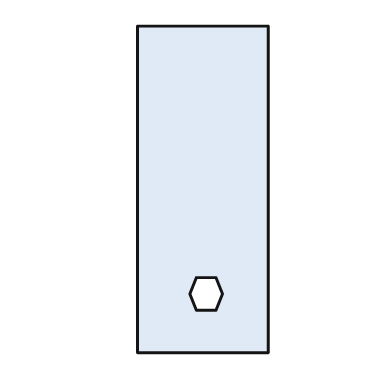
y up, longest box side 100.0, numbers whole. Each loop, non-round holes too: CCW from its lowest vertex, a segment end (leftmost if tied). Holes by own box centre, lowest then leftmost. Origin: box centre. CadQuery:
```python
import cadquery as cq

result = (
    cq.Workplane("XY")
    .moveTo(-20.0, -50.0)
    .lineTo(20.0, -50.0)
    .lineTo(20.0, 50.0)
    .lineTo(-20.0, 50.0)
    .close()
    .moveTo(-2.0, -37.0)
    .lineTo(4.0, -37.0)
    .lineTo(6.0, -32.0)
    .lineTo(4.0, -27.0)
    .lineTo(-2.0, -27.0)
    .lineTo(-4.0, -32.0)
    .close()
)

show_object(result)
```